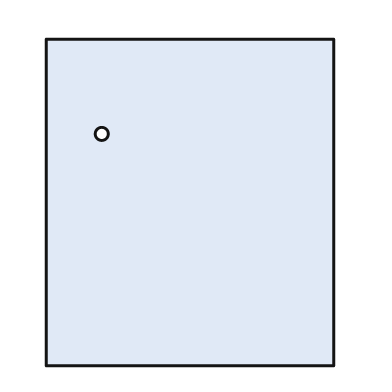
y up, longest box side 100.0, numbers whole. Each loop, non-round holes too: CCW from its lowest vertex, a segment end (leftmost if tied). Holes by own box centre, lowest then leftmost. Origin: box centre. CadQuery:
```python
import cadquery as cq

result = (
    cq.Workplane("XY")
    .moveTo(-44.0, -50.0)
    .lineTo(44.0, -50.0)
    .lineTo(44.0, 50.0)
    .lineTo(-44.0, 50.0)
    .close()
    .moveTo(-27.0, 21.0)
    .circle(2.0)
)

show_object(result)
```